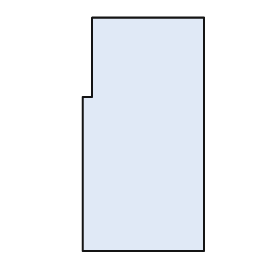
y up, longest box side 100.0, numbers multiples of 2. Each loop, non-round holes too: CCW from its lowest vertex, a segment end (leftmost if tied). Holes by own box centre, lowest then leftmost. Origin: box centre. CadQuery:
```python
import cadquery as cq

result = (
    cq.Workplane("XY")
    .moveTo(-26.0, -50.0)
    .lineTo(26.0, -50.0)
    .lineTo(26.0, 50.0)
    .lineTo(-22.0, 50.0)
    .lineTo(-22.0, 16.0)
    .lineTo(-26.0, 16.0)
    .close()
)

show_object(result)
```